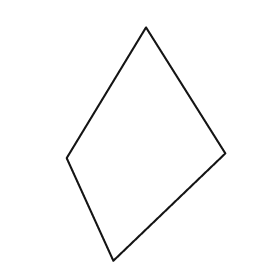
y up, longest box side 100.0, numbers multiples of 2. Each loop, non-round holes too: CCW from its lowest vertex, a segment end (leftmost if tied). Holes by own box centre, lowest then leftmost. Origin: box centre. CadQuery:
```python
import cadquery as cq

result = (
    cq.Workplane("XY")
    .moveTo(-14.0, -50.0)
    .lineTo(34.0, -4.0)
    .lineTo(0.0, 50.0)
    .lineTo(-34.0, -6.0)
    .close()
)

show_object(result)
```